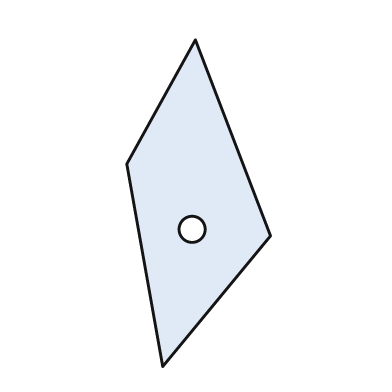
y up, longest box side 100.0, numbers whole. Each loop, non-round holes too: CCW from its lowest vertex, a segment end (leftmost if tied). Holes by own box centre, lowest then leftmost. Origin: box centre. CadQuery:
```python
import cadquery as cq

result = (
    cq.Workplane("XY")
    .moveTo(-11.0, -50.0)
    .lineTo(22.0, -10.0)
    .lineTo(-1.0, 50.0)
    .lineTo(-22.0, 12.0)
    .close()
    .moveTo(-2.0, -8.0)
    .circle(4.0)
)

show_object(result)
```